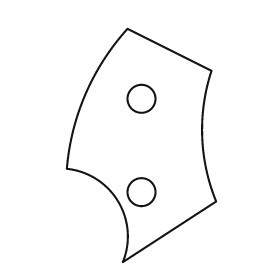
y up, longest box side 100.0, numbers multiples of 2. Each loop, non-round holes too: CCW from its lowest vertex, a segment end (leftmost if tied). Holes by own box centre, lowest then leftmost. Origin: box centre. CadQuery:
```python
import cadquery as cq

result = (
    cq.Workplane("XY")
    .moveTo(-8.0, -50.0)
    .lineTo(32.0, -24.0)
    .threePointArc((26.0, 4.0), (30.0, 32.0))
    .lineTo(-6.0, 50.0)
    .threePointArc((-24.0, 22.0), (-32.0, -10.0))
    .threePointArc((-10.0, -24.0), (-8.0, -50.0))
    .close()
    .moveTo(0.0, -20.0)
    .circle(6.0)
    .moveTo(0.0, 20.0)
    .circle(6.0)
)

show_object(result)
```